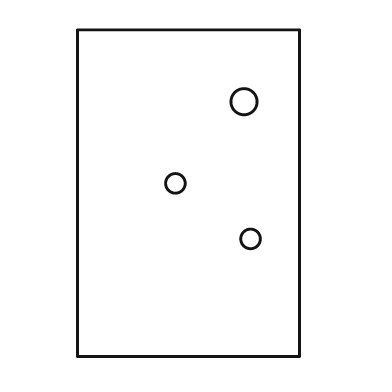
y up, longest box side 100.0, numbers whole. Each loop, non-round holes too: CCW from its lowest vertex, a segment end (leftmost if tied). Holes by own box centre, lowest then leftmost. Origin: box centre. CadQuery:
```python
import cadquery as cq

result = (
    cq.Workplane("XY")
    .moveTo(-34.0, -50.0)
    .lineTo(34.0, -50.0)
    .lineTo(34.0, 50.0)
    .lineTo(-34.0, 50.0)
    .close()
    .moveTo(19.0, -14.0)
    .circle(3.0)
    .moveTo(-4.0, 3.0)
    .circle(3.0)
    .moveTo(17.0, 28.0)
    .circle(4.0)
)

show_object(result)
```